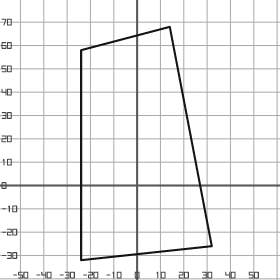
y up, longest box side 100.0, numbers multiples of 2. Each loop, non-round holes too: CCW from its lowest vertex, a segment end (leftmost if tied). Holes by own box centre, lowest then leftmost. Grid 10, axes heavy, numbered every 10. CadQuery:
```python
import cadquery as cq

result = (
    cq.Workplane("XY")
    .moveTo(-24.0, -32.0)
    .lineTo(32.0, -26.0)
    .lineTo(14.0, 68.0)
    .lineTo(-24.0, 58.0)
    .close()
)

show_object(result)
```